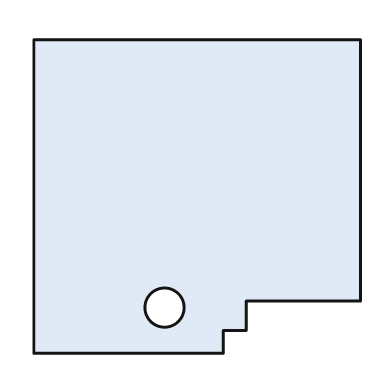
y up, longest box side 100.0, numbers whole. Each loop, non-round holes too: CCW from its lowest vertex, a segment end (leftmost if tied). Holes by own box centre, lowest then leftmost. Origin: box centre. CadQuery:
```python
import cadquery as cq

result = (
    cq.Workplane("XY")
    .moveTo(-50.0, -48.0)
    .lineTo(8.0, -48.0)
    .lineTo(8.0, -41.0)
    .lineTo(15.0, -41.0)
    .lineTo(15.0, -32.0)
    .lineTo(50.0, -32.0)
    .lineTo(50.0, 48.0)
    .lineTo(-50.0, 48.0)
    .close()
    .moveTo(-10.0, -34.0)
    .circle(6.0)
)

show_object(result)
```